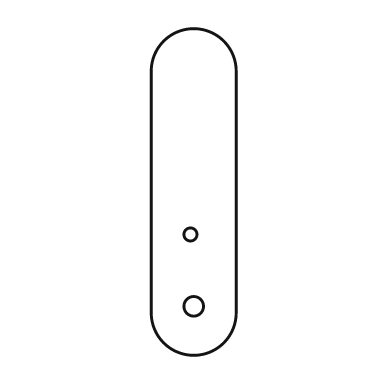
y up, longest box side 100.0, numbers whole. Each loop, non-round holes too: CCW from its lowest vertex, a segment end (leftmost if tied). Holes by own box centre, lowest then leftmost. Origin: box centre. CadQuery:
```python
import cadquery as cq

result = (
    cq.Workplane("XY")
    .moveTo(-13.0, -37.0)
    .threePointArc((0.0, -50.0), (13.0, -37.0))
    .lineTo(13.0, 37.0)
    .threePointArc((0.0, 50.0), (-13.0, 37.0))
    .close()
    .moveTo(0.0, -35.0)
    .circle(3.0)
    .moveTo(-1.0, -13.0)
    .circle(2.0)
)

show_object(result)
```